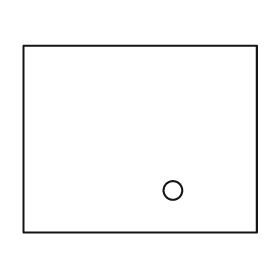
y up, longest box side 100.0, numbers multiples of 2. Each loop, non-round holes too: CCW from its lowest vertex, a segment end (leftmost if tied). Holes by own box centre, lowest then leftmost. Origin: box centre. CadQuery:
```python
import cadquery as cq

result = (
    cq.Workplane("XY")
    .moveTo(-50.0, -40.0)
    .lineTo(50.0, -40.0)
    .lineTo(50.0, 40.0)
    .lineTo(-50.0, 40.0)
    .close()
    .moveTo(14.0, -22.0)
    .circle(4.0)
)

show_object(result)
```